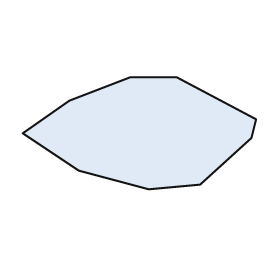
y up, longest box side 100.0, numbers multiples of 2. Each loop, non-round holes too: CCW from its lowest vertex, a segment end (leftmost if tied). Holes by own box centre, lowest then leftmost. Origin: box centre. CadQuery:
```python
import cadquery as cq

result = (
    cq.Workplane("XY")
    .moveTo(4.0, -24.0)
    .lineTo(26.0, -22.0)
    .lineTo(48.0, -2.0)
    .lineTo(50.0, 6.0)
    .lineTo(16.0, 24.0)
    .lineTo(-4.0, 24.0)
    .lineTo(-30.0, 14.0)
    .lineTo(-50.0, 0.0)
    .lineTo(-26.0, -16.0)
    .close()
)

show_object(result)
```